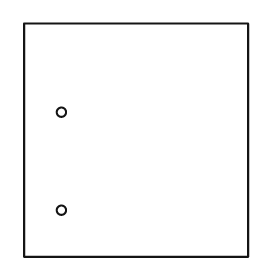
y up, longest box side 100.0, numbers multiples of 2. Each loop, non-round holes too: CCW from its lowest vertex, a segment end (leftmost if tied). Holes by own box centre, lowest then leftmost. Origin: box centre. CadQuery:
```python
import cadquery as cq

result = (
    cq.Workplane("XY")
    .moveTo(-48.0, -50.0)
    .lineTo(48.0, -50.0)
    .lineTo(48.0, 50.0)
    .lineTo(-48.0, 50.0)
    .close()
    .moveTo(-32.0, -30.0)
    .circle(2.0)
    .moveTo(-32.0, 12.0)
    .circle(2.0)
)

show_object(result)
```